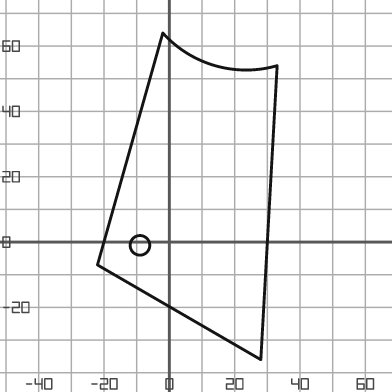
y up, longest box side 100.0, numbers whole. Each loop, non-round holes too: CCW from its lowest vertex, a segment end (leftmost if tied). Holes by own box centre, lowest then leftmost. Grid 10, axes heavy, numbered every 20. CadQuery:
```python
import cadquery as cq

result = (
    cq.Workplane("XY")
    .moveTo(28.0, -36.0)
    .lineTo(33.0, 54.0)
    .threePointArc((14.0, 54.0), (-2.0, 64.0))
    .lineTo(-22.0, -7.0)
    .close()
    .moveTo(-9.0, -1.0)
    .circle(3.0)
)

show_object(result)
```